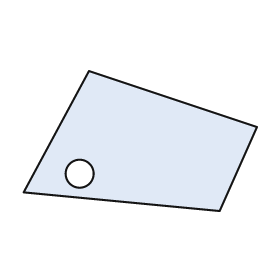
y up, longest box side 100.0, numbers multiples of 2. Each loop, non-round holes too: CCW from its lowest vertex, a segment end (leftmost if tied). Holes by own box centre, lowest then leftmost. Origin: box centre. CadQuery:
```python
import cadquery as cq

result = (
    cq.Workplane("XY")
    .moveTo(34.0, -30.0)
    .lineTo(50.0, 6.0)
    .lineTo(-22.0, 30.0)
    .lineTo(-50.0, -22.0)
    .close()
    .moveTo(-26.0, -14.0)
    .circle(6.0)
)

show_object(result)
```